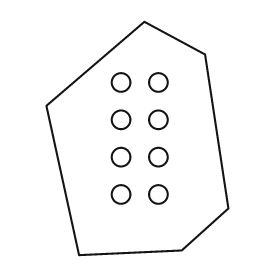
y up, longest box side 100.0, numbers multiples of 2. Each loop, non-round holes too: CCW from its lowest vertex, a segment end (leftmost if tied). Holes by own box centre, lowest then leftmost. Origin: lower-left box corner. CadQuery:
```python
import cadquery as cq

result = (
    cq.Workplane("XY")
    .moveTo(14.0, 0.0)
    .lineTo(58.0, 2.0)
    .lineTo(78.0, 20.0)
    .lineTo(68.0, 86.0)
    .lineTo(42.0, 100.0)
    .lineTo(0.0, 64.0)
    .close()
    .moveTo(32.0, 26.0)
    .circle(4.0)
    .moveTo(48.0, 26.0)
    .circle(4.0)
    .moveTo(32.0, 42.0)
    .circle(4.0)
    .moveTo(48.0, 42.0)
    .circle(4.0)
    .moveTo(32.0, 58.0)
    .circle(4.0)
    .moveTo(48.0, 58.0)
    .circle(4.0)
    .moveTo(32.0, 74.0)
    .circle(4.0)
    .moveTo(48.0, 74.0)
    .circle(4.0)
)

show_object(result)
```